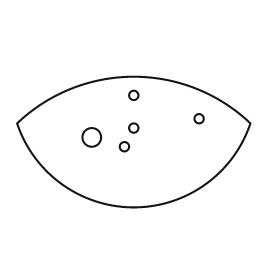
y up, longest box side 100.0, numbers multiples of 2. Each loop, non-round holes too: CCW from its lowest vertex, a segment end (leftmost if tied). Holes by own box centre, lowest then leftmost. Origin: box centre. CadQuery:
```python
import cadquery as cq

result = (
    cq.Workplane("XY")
    .moveTo(-50.0, 8.0)
    .threePointArc((0.0, -28.0), (50.0, 8.0))
    .threePointArc((0.0, 28.0), (-50.0, 8.0))
    .close()
    .moveTo(-4.0, -2.0)
    .circle(2.0)
    .moveTo(-18.0, 2.0)
    .circle(4.0)
    .moveTo(0.0, 6.0)
    .circle(2.0)
    .moveTo(28.0, 10.0)
    .circle(2.0)
    .moveTo(0.0, 20.0)
    .circle(2.0)
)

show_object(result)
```